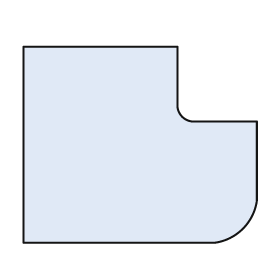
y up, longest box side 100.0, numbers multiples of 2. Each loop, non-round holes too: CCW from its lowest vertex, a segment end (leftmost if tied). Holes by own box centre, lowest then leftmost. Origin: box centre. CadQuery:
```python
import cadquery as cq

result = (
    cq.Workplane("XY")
    .moveTo(-50.0, -42.0)
    .lineTo(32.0, -42.0)
    .threePointArc((44.0, -36.0), (50.0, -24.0))
    .lineTo(50.0, 10.0)
    .lineTo(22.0, 10.0)
    .threePointArc((18.0, 12.0), (16.0, 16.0))
    .lineTo(16.0, 42.0)
    .lineTo(-50.0, 42.0)
    .close()
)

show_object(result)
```